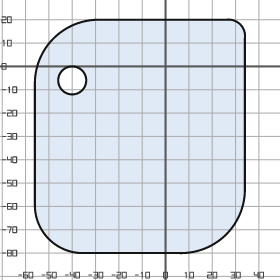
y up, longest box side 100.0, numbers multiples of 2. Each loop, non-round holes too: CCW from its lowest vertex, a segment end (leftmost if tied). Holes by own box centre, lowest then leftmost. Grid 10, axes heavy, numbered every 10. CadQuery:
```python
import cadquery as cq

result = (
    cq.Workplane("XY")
    .moveTo(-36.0, -80.0)
    .lineTo(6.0, -80.0)
    .threePointArc((26.0, -72.0), (34.0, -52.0))
    .lineTo(34.0, 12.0)
    .threePointArc((32.0, 18.0), (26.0, 20.0))
    .lineTo(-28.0, 20.0)
    .threePointArc((-48.0, 12.0), (-56.0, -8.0))
    .lineTo(-56.0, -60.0)
    .threePointArc((-50.0, -74.0), (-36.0, -80.0))
    .close()
    .moveTo(-40.0, -6.0)
    .circle(6.0)
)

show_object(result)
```